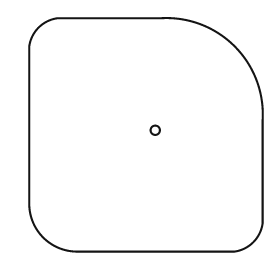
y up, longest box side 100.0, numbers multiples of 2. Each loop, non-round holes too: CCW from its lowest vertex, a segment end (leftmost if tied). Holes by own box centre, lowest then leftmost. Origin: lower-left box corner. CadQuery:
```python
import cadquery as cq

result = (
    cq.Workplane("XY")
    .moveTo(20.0, 0.0)
    .lineTo(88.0, 0.0)
    .threePointArc((96.0, 4.0), (100.0, 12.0))
    .lineTo(100.0, 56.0)
    .threePointArc((88.0, 88.0), (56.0, 100.0))
    .lineTo(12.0, 100.0)
    .threePointArc((4.0, 96.0), (0.0, 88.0))
    .lineTo(0.0, 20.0)
    .threePointArc((6.0, 6.0), (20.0, 0.0))
    .close()
    .moveTo(54.0, 52.0)
    .circle(2.0)
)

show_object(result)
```